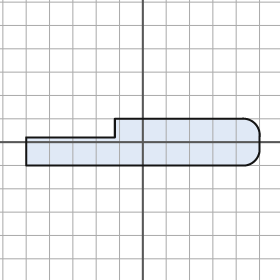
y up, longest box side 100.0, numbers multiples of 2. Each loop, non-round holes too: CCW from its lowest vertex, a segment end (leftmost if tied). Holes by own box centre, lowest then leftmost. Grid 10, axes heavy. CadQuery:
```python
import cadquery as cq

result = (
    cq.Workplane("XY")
    .moveTo(-50.0, -10.0)
    .lineTo(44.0, -10.0)
    .threePointArc((48.0, -8.0), (50.0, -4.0))
    .lineTo(50.0, 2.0)
    .threePointArc((48.0, 8.0), (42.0, 10.0))
    .lineTo(-12.0, 10.0)
    .lineTo(-12.0, 2.0)
    .lineTo(-50.0, 2.0)
    .close()
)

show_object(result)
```